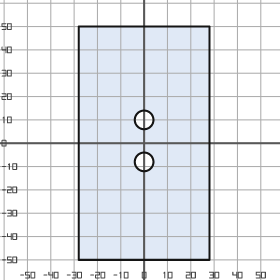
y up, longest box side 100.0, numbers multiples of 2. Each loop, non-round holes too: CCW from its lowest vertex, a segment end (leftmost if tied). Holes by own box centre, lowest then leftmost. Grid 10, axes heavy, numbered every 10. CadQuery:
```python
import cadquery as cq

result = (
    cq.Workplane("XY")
    .moveTo(-28.0, -50.0)
    .lineTo(28.0, -50.0)
    .lineTo(28.0, 50.0)
    .lineTo(-28.0, 50.0)
    .close()
    .moveTo(0.0, -8.0)
    .circle(4.0)
    .moveTo(0.0, 10.0)
    .circle(4.0)
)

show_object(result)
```